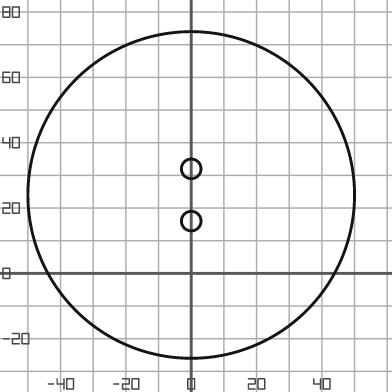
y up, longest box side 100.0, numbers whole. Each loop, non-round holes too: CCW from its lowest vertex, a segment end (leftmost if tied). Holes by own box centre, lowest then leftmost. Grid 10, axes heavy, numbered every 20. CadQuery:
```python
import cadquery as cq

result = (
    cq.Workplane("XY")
    .moveTo(0.0, 24.0)
    .circle(50.0)
    .moveTo(0.0, 16.0)
    .circle(3.0)
    .moveTo(0.0, 32.0)
    .circle(3.0)
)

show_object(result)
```